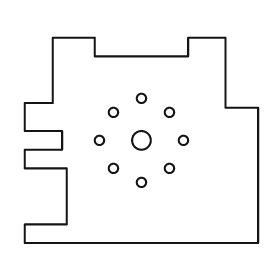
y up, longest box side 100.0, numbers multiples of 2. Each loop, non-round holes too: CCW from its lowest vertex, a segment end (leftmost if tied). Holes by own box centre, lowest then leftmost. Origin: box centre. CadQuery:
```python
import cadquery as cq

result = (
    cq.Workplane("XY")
    .moveTo(-50.0, -44.0)
    .lineTo(50.0, -44.0)
    .lineTo(50.0, 14.0)
    .lineTo(36.0, 14.0)
    .lineTo(36.0, 44.0)
    .lineTo(20.0, 44.0)
    .lineTo(20.0, 36.0)
    .lineTo(-20.0, 36.0)
    .lineTo(-20.0, 44.0)
    .lineTo(-38.0, 44.0)
    .lineTo(-38.0, 16.0)
    .lineTo(-50.0, 16.0)
    .lineTo(-50.0, 4.0)
    .lineTo(-34.0, 4.0)
    .lineTo(-34.0, -4.0)
    .lineTo(-50.0, -4.0)
    .lineTo(-50.0, -12.0)
    .lineTo(-32.0, -12.0)
    .lineTo(-32.0, -36.0)
    .lineTo(-50.0, -36.0)
    .close()
    .moveTo(0.0, -18.0)
    .circle(2.0)
    .moveTo(-12.0, -12.0)
    .circle(2.0)
    .moveTo(12.0, -12.0)
    .circle(2.0)
    .moveTo(-18.0, 0.0)
    .circle(2.0)
    .moveTo(0.0, 0.0)
    .circle(4.0)
    .moveTo(18.0, 0.0)
    .circle(2.0)
    .moveTo(-12.0, 12.0)
    .circle(2.0)
    .moveTo(12.0, 12.0)
    .circle(2.0)
    .moveTo(0.0, 18.0)
    .circle(2.0)
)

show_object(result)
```